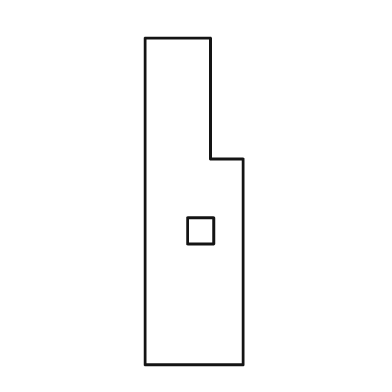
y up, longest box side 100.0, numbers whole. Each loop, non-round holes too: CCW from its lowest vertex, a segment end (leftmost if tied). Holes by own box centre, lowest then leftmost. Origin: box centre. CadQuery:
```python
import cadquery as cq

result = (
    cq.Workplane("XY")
    .moveTo(-15.0, -50.0)
    .lineTo(15.0, -50.0)
    .lineTo(15.0, 13.0)
    .lineTo(5.0, 13.0)
    .lineTo(5.0, 50.0)
    .lineTo(-15.0, 50.0)
    .close()
    .moveTo(-2.0, -13.0)
    .lineTo(6.0, -13.0)
    .lineTo(6.0, -5.0)
    .lineTo(-2.0, -5.0)
    .close()
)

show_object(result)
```